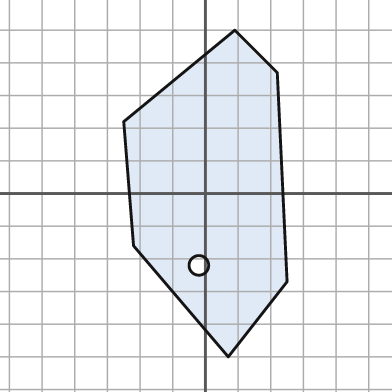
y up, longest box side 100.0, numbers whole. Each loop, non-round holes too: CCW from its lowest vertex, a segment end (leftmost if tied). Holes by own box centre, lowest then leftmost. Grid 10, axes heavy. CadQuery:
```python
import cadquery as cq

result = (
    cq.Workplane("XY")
    .moveTo(7.0, -50.0)
    .lineTo(25.0, -27.0)
    .lineTo(22.0, 37.0)
    .lineTo(9.0, 50.0)
    .lineTo(-25.0, 22.0)
    .lineTo(-22.0, -16.0)
    .close()
    .moveTo(-2.0, -22.0)
    .circle(3.0)
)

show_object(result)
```